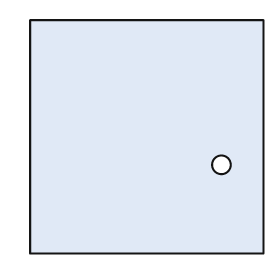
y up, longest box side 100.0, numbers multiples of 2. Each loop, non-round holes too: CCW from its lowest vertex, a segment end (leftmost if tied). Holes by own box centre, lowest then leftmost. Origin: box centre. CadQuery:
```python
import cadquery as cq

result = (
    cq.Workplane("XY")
    .moveTo(-50.0, -50.0)
    .lineTo(50.0, -50.0)
    .lineTo(50.0, 50.0)
    .lineTo(-50.0, 50.0)
    .close()
    .moveTo(32.0, -12.0)
    .circle(4.0)
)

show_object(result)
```